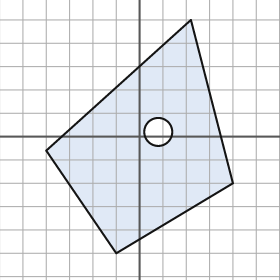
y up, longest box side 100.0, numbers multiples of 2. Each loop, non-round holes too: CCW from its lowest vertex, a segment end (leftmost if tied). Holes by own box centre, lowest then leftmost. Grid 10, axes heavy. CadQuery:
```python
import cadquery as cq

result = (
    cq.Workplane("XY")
    .moveTo(-10.0, -50.0)
    .lineTo(40.0, -20.0)
    .lineTo(22.0, 50.0)
    .lineTo(-40.0, -6.0)
    .close()
    .moveTo(8.0, 2.0)
    .circle(6.0)
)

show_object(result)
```